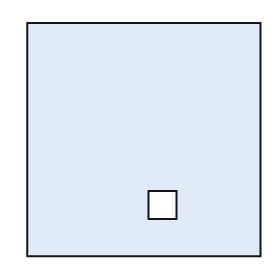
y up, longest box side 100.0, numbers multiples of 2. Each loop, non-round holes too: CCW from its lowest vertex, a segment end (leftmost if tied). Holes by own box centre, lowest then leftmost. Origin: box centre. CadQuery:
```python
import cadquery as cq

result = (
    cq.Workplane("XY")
    .moveTo(-50.0, -50.0)
    .lineTo(50.0, -50.0)
    .lineTo(50.0, 50.0)
    .lineTo(-50.0, 50.0)
    .close()
    .moveTo(2.0, -34.0)
    .lineTo(14.0, -34.0)
    .lineTo(14.0, -22.0)
    .lineTo(2.0, -22.0)
    .close()
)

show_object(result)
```